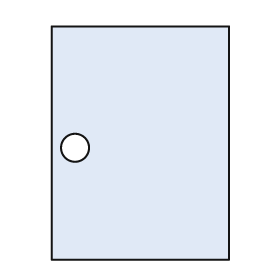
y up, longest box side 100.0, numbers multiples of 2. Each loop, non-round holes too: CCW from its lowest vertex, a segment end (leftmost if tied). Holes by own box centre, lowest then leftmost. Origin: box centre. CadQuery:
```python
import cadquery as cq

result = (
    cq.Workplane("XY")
    .moveTo(-38.0, -50.0)
    .lineTo(38.0, -50.0)
    .lineTo(38.0, 50.0)
    .lineTo(-38.0, 50.0)
    .close()
    .moveTo(-28.0, -2.0)
    .circle(6.0)
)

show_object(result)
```